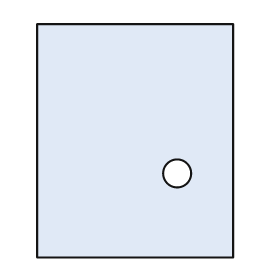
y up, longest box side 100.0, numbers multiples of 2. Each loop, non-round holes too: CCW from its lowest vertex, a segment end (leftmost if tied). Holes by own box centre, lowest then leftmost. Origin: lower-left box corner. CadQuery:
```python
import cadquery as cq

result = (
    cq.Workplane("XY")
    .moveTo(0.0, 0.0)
    .lineTo(84.0, 0.0)
    .lineTo(84.0, 100.0)
    .lineTo(0.0, 100.0)
    .close()
    .moveTo(60.0, 36.0)
    .circle(6.0)
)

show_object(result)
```